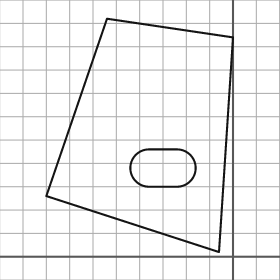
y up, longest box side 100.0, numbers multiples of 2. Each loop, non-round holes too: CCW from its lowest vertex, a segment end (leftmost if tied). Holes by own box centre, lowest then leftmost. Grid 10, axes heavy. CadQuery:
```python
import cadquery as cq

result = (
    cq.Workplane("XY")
    .moveTo(-6.0, 2.0)
    .lineTo(0.0, 94.0)
    .lineTo(-54.0, 102.0)
    .lineTo(-80.0, 26.0)
    .close()
    .moveTo(-36.0, 30.0)
    .lineTo(-24.0, 30.0)
    .threePointArc((-16.0, 38.0), (-24.0, 46.0))
    .lineTo(-36.0, 46.0)
    .threePointArc((-44.0, 38.0), (-36.0, 30.0))
    .close()
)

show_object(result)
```